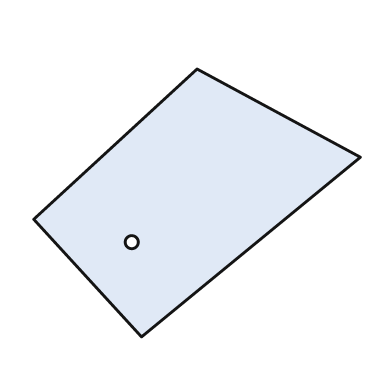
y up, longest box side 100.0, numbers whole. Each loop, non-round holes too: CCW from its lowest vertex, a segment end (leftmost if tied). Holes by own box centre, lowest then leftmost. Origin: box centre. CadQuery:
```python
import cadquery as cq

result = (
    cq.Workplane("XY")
    .moveTo(-17.0, -41.0)
    .lineTo(50.0, 14.0)
    .lineTo(0.0, 41.0)
    .lineTo(-50.0, -5.0)
    .close()
    .moveTo(-20.0, -12.0)
    .circle(2.0)
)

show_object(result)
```